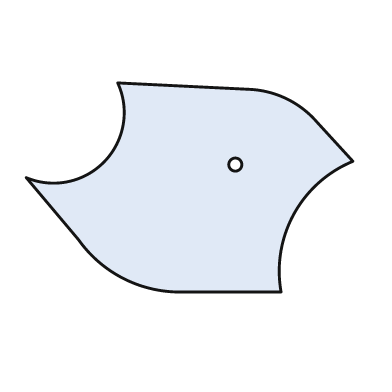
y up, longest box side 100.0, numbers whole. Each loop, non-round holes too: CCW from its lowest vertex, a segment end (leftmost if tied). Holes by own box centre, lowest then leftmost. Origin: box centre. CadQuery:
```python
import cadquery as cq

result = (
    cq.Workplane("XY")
    .moveTo(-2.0, -32.0)
    .lineTo(28.0, -32.0)
    .threePointArc((32.0, -8.0), (50.0, 8.0))
    .lineTo(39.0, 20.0)
    .threePointArc((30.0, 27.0), (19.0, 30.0))
    .lineTo(-22.0, 32.0)
    .threePointArc((-26.0, 8.0), (-50.0, 3.0))
    .lineTo(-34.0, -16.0)
    .threePointArc((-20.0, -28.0), (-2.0, -32.0))
    .close()
    .moveTo(14.0, 7.0)
    .circle(2.0)
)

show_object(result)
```